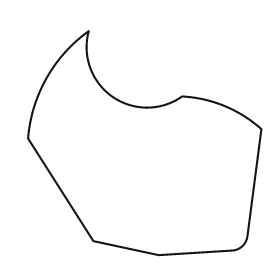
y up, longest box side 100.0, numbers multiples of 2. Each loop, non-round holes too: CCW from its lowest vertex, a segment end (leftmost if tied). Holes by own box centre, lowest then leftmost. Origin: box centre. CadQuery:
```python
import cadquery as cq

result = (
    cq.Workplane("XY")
    .moveTo(6.0, -48.0)
    .lineTo(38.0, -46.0)
    .threePointArc((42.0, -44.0), (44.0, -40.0))
    .lineTo(50.0, 6.0)
    .threePointArc((34.0, 16.0), (16.0, 20.0))
    .threePointArc((-14.0, 20.0), (-24.0, 48.0))
    .threePointArc((-42.0, 28.0), (-50.0, 2.0))
    .lineTo(-22.0, -42.0)
    .close()
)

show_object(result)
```